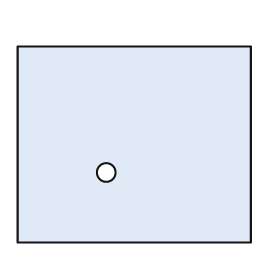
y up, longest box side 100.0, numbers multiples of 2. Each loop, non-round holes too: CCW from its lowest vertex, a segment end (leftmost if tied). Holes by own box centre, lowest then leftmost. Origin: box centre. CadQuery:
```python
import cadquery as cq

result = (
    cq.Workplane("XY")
    .moveTo(-50.0, -42.0)
    .lineTo(50.0, -42.0)
    .lineTo(50.0, 42.0)
    .lineTo(-50.0, 42.0)
    .close()
    .moveTo(-12.0, -12.0)
    .circle(4.0)
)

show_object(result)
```